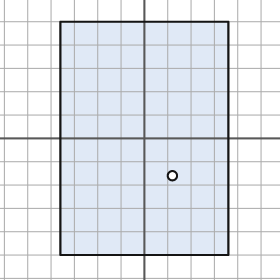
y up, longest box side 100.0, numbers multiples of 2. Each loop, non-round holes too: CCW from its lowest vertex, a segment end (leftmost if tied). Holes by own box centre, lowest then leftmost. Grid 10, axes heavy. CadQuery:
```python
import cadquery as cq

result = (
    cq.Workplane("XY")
    .moveTo(-36.0, -50.0)
    .lineTo(36.0, -50.0)
    .lineTo(36.0, 50.0)
    .lineTo(-36.0, 50.0)
    .close()
    .moveTo(12.0, -16.0)
    .circle(2.0)
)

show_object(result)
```